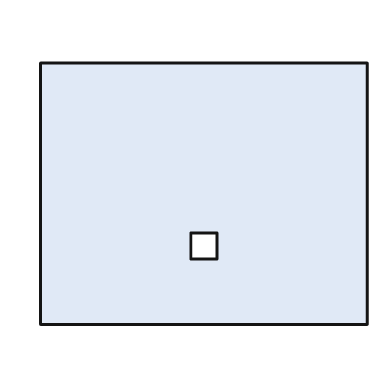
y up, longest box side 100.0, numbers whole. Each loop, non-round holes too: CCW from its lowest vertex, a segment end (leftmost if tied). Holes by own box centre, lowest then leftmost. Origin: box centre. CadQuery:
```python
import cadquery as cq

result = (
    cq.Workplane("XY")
    .moveTo(-50.0, -40.0)
    .lineTo(50.0, -40.0)
    .lineTo(50.0, 40.0)
    .lineTo(-50.0, 40.0)
    .close()
    .moveTo(-4.0, -20.0)
    .lineTo(4.0, -20.0)
    .lineTo(4.0, -12.0)
    .lineTo(-4.0, -12.0)
    .close()
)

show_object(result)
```